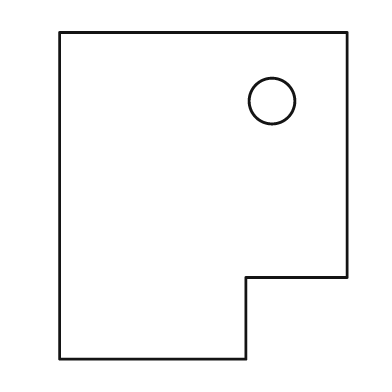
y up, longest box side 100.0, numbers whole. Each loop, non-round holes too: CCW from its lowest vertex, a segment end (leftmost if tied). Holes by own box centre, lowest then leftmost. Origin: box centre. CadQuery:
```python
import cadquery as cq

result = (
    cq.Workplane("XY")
    .moveTo(-44.0, -50.0)
    .lineTo(13.0, -50.0)
    .lineTo(13.0, -25.0)
    .lineTo(44.0, -25.0)
    .lineTo(44.0, 50.0)
    .lineTo(-44.0, 50.0)
    .close()
    .moveTo(21.0, 29.0)
    .circle(7.0)
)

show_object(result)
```